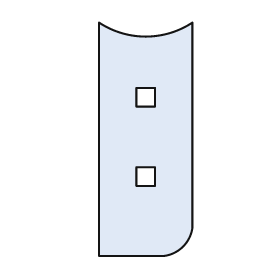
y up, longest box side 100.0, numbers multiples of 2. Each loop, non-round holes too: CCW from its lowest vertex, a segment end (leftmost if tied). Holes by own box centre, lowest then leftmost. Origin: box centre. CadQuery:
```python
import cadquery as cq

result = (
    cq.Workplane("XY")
    .moveTo(-20.0, -50.0)
    .lineTo(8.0, -50.0)
    .threePointArc((16.0, -46.0), (20.0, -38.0))
    .lineTo(20.0, 50.0)
    .threePointArc((0.0, 44.0), (-20.0, 50.0))
    .close()
    .moveTo(-4.0, -20.0)
    .lineTo(4.0, -20.0)
    .lineTo(4.0, -12.0)
    .lineTo(-4.0, -12.0)
    .close()
    .moveTo(-4.0, 14.0)
    .lineTo(4.0, 14.0)
    .lineTo(4.0, 22.0)
    .lineTo(-4.0, 22.0)
    .close()
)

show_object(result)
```